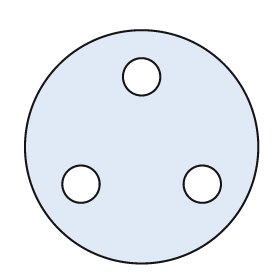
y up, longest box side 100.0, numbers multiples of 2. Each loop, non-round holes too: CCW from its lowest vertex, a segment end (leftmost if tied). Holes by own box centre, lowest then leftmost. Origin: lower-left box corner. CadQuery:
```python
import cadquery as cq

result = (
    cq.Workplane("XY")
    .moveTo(50.0, 50.0)
    .circle(50.0)
    .moveTo(24.0, 34.0)
    .circle(8.0)
    .moveTo(76.0, 34.0)
    .circle(8.0)
    .moveTo(50.0, 80.0)
    .circle(8.0)
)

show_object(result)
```